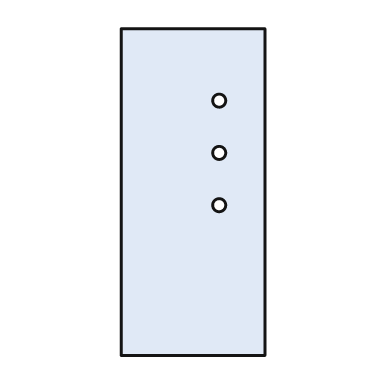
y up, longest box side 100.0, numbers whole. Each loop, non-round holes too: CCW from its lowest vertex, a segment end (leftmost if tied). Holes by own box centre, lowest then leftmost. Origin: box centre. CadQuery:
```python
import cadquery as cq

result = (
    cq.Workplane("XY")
    .moveTo(-22.0, -50.0)
    .lineTo(22.0, -50.0)
    .lineTo(22.0, 50.0)
    .lineTo(-22.0, 50.0)
    .close()
    .moveTo(8.0, -4.0)
    .circle(2.0)
    .moveTo(8.0, 12.0)
    .circle(2.0)
    .moveTo(8.0, 28.0)
    .circle(2.0)
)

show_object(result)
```